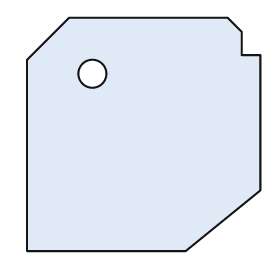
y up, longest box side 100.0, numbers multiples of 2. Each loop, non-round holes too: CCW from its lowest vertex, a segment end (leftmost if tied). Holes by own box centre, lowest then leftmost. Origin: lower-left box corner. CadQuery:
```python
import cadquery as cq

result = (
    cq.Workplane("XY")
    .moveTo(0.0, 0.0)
    .lineTo(68.0, 0.0)
    .lineTo(100.0, 26.0)
    .lineTo(100.0, 84.0)
    .lineTo(92.0, 84.0)
    .lineTo(92.0, 94.0)
    .lineTo(86.0, 100.0)
    .lineTo(18.0, 100.0)
    .lineTo(0.0, 82.0)
    .close()
    .moveTo(28.0, 76.0)
    .circle(6.0)
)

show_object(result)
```